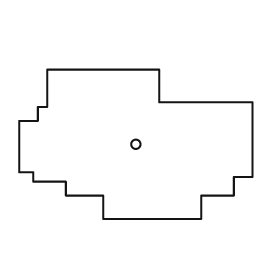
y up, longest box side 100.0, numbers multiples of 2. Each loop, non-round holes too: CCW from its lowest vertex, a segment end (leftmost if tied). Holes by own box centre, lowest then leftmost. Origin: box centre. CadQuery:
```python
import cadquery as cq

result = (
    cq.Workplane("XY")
    .moveTo(-14.0, -32.0)
    .lineTo(28.0, -32.0)
    .lineTo(28.0, -22.0)
    .lineTo(42.0, -22.0)
    .lineTo(42.0, -14.0)
    .lineTo(50.0, -14.0)
    .lineTo(50.0, 18.0)
    .lineTo(10.0, 18.0)
    .lineTo(10.0, 32.0)
    .lineTo(-38.0, 32.0)
    .lineTo(-38.0, 16.0)
    .lineTo(-42.0, 16.0)
    .lineTo(-42.0, 10.0)
    .lineTo(-50.0, 10.0)
    .lineTo(-50.0, -12.0)
    .lineTo(-44.0, -12.0)
    .lineTo(-44.0, -16.0)
    .lineTo(-30.0, -16.0)
    .lineTo(-30.0, -22.0)
    .lineTo(-14.0, -22.0)
    .close()
    .moveTo(0.0, 0.0)
    .circle(2.0)
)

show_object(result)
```